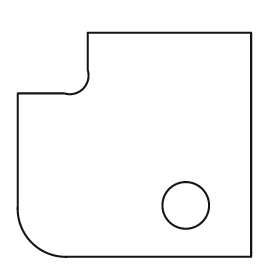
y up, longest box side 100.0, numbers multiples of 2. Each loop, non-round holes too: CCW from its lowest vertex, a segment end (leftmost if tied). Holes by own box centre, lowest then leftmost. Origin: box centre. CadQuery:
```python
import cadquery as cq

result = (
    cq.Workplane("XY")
    .moveTo(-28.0, -48.0)
    .lineTo(50.0, -48.0)
    .lineTo(50.0, 48.0)
    .lineTo(-20.0, 48.0)
    .lineTo(-20.0, 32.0)
    .threePointArc((-22.0, 24.0), (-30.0, 22.0))
    .lineTo(-50.0, 22.0)
    .lineTo(-50.0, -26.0)
    .threePointArc((-44.0, -42.0), (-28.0, -48.0))
    .close()
    .moveTo(22.0, -26.0)
    .circle(10.0)
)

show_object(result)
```